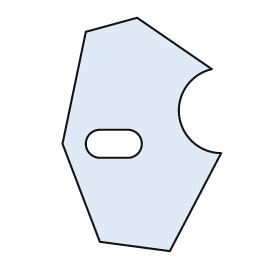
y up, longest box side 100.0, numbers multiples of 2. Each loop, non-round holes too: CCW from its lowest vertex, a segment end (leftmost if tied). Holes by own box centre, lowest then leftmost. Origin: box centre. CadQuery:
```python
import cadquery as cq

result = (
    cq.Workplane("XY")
    .moveTo(12.0, -50.0)
    .lineTo(34.0, -8.0)
    .threePointArc((16.0, 8.0), (30.0, 28.0))
    .lineTo(-2.0, 50.0)
    .lineTo(-24.0, 44.0)
    .lineTo(-34.0, -4.0)
    .lineTo(-18.0, -46.0)
    .close()
    .moveTo(-18.0, -10.0)
    .lineTo(-6.0, -10.0)
    .threePointArc((0.0, -4.0), (-6.0, 2.0))
    .lineTo(-18.0, 2.0)
    .threePointArc((-24.0, -4.0), (-18.0, -10.0))
    .close()
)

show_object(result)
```